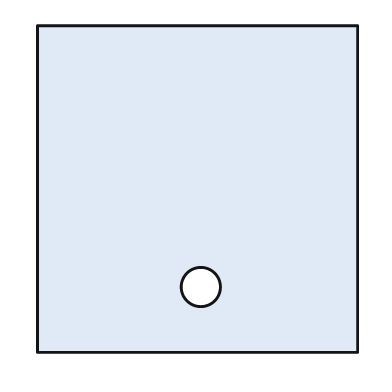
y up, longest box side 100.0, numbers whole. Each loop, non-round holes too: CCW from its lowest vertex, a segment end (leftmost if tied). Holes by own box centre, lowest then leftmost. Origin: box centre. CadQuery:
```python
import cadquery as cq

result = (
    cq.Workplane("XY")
    .moveTo(-49.0, -50.0)
    .lineTo(49.0, -50.0)
    .lineTo(49.0, 50.0)
    .lineTo(-49.0, 50.0)
    .close()
    .moveTo(1.0, -30.0)
    .circle(6.0)
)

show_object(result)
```